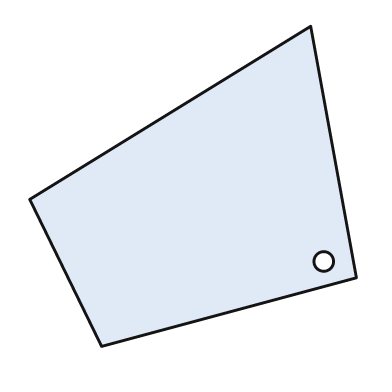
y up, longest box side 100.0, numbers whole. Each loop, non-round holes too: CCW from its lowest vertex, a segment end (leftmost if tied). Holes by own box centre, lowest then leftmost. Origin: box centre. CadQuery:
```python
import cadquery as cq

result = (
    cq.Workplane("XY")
    .moveTo(-28.0, -49.0)
    .lineTo(50.0, -28.0)
    .lineTo(36.0, 49.0)
    .lineTo(-50.0, -4.0)
    .close()
    .moveTo(40.0, -23.0)
    .circle(3.0)
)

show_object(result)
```